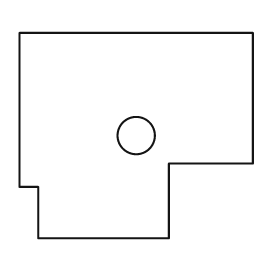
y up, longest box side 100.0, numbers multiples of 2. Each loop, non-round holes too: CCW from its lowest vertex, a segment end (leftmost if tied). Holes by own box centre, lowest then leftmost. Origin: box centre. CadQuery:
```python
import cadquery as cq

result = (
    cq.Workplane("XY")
    .moveTo(-42.0, -44.0)
    .lineTo(14.0, -44.0)
    .lineTo(14.0, -12.0)
    .lineTo(50.0, -12.0)
    .lineTo(50.0, 44.0)
    .lineTo(-50.0, 44.0)
    .lineTo(-50.0, -22.0)
    .lineTo(-42.0, -22.0)
    .close()
    .moveTo(0.0, 0.0)
    .circle(8.0)
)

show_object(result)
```